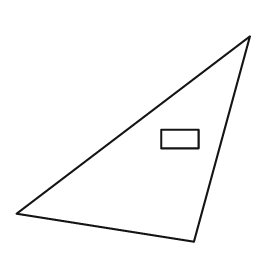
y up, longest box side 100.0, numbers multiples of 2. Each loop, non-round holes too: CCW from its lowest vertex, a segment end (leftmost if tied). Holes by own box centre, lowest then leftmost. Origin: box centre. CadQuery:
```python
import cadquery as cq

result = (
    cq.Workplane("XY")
    .moveTo(26.0, -44.0)
    .lineTo(50.0, 44.0)
    .lineTo(-50.0, -32.0)
    .close()
    .moveTo(12.0, -4.0)
    .lineTo(28.0, -4.0)
    .lineTo(28.0, 4.0)
    .lineTo(12.0, 4.0)
    .close()
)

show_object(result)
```